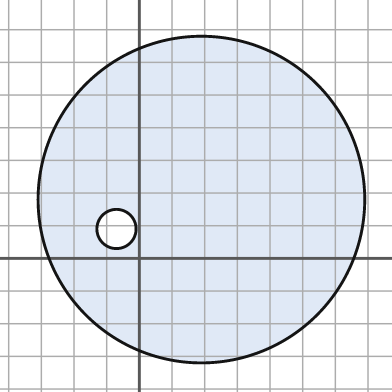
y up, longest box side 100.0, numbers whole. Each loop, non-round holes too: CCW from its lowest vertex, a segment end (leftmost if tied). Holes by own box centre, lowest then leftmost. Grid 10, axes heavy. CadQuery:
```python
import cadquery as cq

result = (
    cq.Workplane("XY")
    .moveTo(19.0, 18.0)
    .circle(50.0)
    .moveTo(-7.0, 9.0)
    .circle(6.0)
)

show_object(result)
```